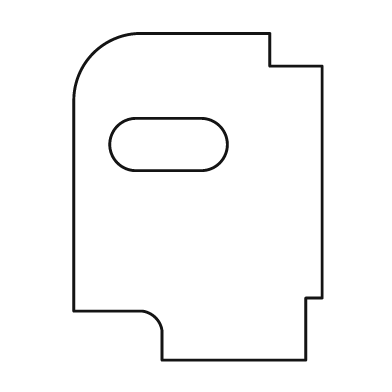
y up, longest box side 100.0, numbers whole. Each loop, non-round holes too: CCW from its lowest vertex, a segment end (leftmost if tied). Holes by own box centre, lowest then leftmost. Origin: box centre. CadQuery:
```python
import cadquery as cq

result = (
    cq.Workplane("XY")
    .moveTo(-11.0, -50.0)
    .lineTo(33.0, -50.0)
    .lineTo(33.0, -31.0)
    .lineTo(38.0, -31.0)
    .lineTo(38.0, 40.0)
    .lineTo(22.0, 40.0)
    .lineTo(22.0, 50.0)
    .lineTo(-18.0, 50.0)
    .threePointArc((-32.0, 44.0), (-38.0, 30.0))
    .lineTo(-38.0, -35.0)
    .lineTo(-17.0, -35.0)
    .threePointArc((-13.0, -37.0), (-11.0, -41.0))
    .close()
    .moveTo(-19.0, 8.0)
    .lineTo(1.0, 8.0)
    .threePointArc((9.0, 16.0), (1.0, 24.0))
    .lineTo(-19.0, 24.0)
    .threePointArc((-27.0, 16.0), (-19.0, 8.0))
    .close()
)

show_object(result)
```